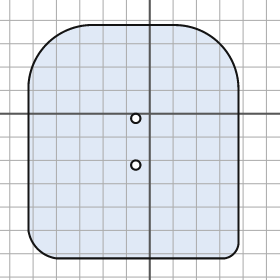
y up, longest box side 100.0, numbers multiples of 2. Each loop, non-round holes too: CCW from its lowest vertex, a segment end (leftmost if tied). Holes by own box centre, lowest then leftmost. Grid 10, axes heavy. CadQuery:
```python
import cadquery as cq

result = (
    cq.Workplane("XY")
    .moveTo(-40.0, -62.0)
    .lineTo(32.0, -62.0)
    .threePointArc((36.0, -60.0), (38.0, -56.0))
    .lineTo(38.0, 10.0)
    .threePointArc((30.0, 30.0), (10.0, 38.0))
    .lineTo(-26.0, 38.0)
    .threePointArc((-44.0, 30.0), (-52.0, 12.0))
    .lineTo(-52.0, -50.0)
    .threePointArc((-48.0, -58.0), (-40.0, -62.0))
    .close()
    .moveTo(-6.0, -22.0)
    .circle(2.0)
    .moveTo(-6.0, -2.0)
    .circle(2.0)
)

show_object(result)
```